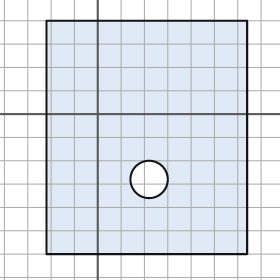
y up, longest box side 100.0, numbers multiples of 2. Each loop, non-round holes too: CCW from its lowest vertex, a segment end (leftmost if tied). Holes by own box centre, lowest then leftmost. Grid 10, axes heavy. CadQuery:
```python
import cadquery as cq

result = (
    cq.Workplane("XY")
    .moveTo(-22.0, -60.0)
    .lineTo(64.0, -60.0)
    .lineTo(64.0, 40.0)
    .lineTo(-22.0, 40.0)
    .close()
    .moveTo(22.0, -28.0)
    .circle(8.0)
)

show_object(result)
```